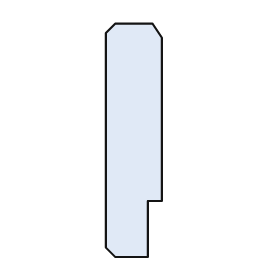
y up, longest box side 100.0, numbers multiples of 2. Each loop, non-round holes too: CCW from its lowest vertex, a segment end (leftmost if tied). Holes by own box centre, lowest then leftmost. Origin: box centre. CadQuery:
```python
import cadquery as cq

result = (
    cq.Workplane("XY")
    .moveTo(-8.0, -50.0)
    .lineTo(6.0, -50.0)
    .lineTo(6.0, -26.0)
    .lineTo(12.0, -26.0)
    .lineTo(12.0, 44.0)
    .lineTo(8.0, 50.0)
    .lineTo(-8.0, 50.0)
    .lineTo(-12.0, 46.0)
    .lineTo(-12.0, -46.0)
    .close()
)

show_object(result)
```